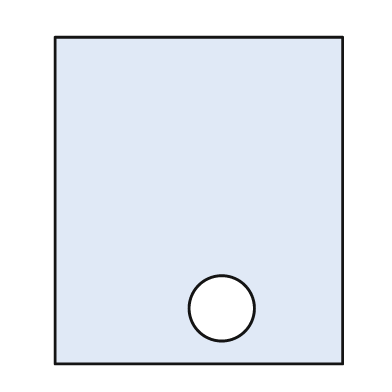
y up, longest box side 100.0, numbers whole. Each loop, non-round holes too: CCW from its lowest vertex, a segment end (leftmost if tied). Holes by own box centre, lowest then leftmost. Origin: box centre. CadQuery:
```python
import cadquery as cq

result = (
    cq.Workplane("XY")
    .moveTo(-44.0, -50.0)
    .lineTo(44.0, -50.0)
    .lineTo(44.0, 50.0)
    .lineTo(-44.0, 50.0)
    .close()
    .moveTo(7.0, -33.0)
    .circle(10.0)
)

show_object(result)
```